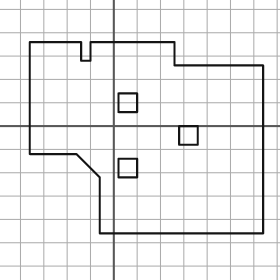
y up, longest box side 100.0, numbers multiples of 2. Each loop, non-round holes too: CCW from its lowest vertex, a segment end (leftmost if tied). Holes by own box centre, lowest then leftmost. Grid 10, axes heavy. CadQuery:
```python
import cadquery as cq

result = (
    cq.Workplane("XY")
    .moveTo(-6.0, -46.0)
    .lineTo(64.0, -46.0)
    .lineTo(64.0, 26.0)
    .lineTo(26.0, 26.0)
    .lineTo(26.0, 36.0)
    .lineTo(-10.0, 36.0)
    .lineTo(-10.0, 28.0)
    .lineTo(-14.0, 28.0)
    .lineTo(-14.0, 36.0)
    .lineTo(-36.0, 36.0)
    .lineTo(-36.0, -12.0)
    .lineTo(-16.0, -12.0)
    .lineTo(-6.0, -22.0)
    .close()
    .moveTo(2.0, -22.0)
    .lineTo(10.0, -22.0)
    .lineTo(10.0, -14.0)
    .lineTo(2.0, -14.0)
    .close()
    .moveTo(28.0, -8.0)
    .lineTo(36.0, -8.0)
    .lineTo(36.0, 0.0)
    .lineTo(28.0, 0.0)
    .close()
    .moveTo(2.0, 6.0)
    .lineTo(10.0, 6.0)
    .lineTo(10.0, 14.0)
    .lineTo(2.0, 14.0)
    .close()
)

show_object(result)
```